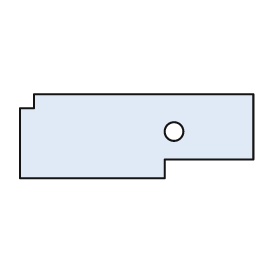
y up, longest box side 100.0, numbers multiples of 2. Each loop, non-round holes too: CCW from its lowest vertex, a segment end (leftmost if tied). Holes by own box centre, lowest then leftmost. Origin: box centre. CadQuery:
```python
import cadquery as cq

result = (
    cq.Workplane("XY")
    .moveTo(-50.0, -18.0)
    .lineTo(12.0, -18.0)
    .lineTo(12.0, -10.0)
    .lineTo(50.0, -10.0)
    .lineTo(50.0, 18.0)
    .lineTo(-44.0, 18.0)
    .lineTo(-44.0, 12.0)
    .lineTo(-50.0, 12.0)
    .close()
    .moveTo(16.0, 2.0)
    .circle(4.0)
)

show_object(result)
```